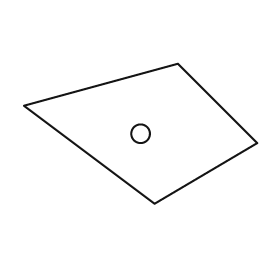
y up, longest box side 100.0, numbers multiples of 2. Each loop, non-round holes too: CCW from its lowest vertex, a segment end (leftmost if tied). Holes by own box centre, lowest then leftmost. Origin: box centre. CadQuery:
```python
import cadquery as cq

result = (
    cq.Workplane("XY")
    .moveTo(6.0, -30.0)
    .lineTo(50.0, -4.0)
    .lineTo(16.0, 30.0)
    .lineTo(-50.0, 12.0)
    .close()
    .moveTo(0.0, 0.0)
    .circle(4.0)
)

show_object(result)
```